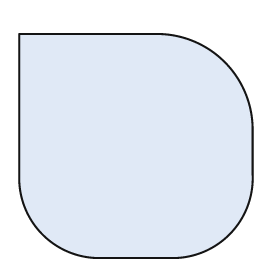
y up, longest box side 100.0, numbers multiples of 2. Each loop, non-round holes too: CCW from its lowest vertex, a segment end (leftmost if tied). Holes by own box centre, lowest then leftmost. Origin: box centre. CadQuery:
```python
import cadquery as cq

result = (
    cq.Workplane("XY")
    .moveTo(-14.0, -48.0)
    .lineTo(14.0, -48.0)
    .threePointArc((40.0, -38.0), (50.0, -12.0))
    .lineTo(50.0, 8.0)
    .threePointArc((38.0, 36.0), (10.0, 48.0))
    .lineTo(-50.0, 48.0)
    .lineTo(-50.0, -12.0)
    .threePointArc((-40.0, -38.0), (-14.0, -48.0))
    .close()
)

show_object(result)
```